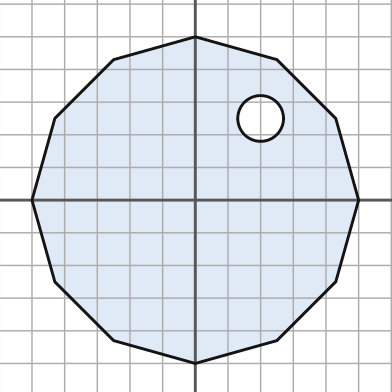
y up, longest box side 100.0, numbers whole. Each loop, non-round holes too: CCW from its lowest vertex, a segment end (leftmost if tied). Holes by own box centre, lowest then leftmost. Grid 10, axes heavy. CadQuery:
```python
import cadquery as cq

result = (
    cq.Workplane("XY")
    .moveTo(0.0, -50.0)
    .lineTo(25.0, -43.0)
    .lineTo(43.0, -25.0)
    .lineTo(50.0, 0.0)
    .lineTo(43.0, 25.0)
    .lineTo(25.0, 43.0)
    .lineTo(0.0, 50.0)
    .lineTo(-25.0, 43.0)
    .lineTo(-43.0, 25.0)
    .lineTo(-50.0, 0.0)
    .lineTo(-43.0, -25.0)
    .lineTo(-25.0, -43.0)
    .close()
    .moveTo(20.0, 25.0)
    .circle(7.0)
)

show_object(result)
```